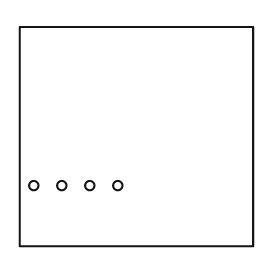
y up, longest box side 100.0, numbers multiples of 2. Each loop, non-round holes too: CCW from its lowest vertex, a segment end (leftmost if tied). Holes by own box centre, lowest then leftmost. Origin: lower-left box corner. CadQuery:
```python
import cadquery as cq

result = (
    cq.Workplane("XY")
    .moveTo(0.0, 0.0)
    .lineTo(100.0, 0.0)
    .lineTo(100.0, 94.0)
    .lineTo(0.0, 94.0)
    .close()
    .moveTo(6.0, 26.0)
    .circle(2.0)
    .moveTo(18.0, 26.0)
    .circle(2.0)
    .moveTo(30.0, 26.0)
    .circle(2.0)
    .moveTo(42.0, 26.0)
    .circle(2.0)
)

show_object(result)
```